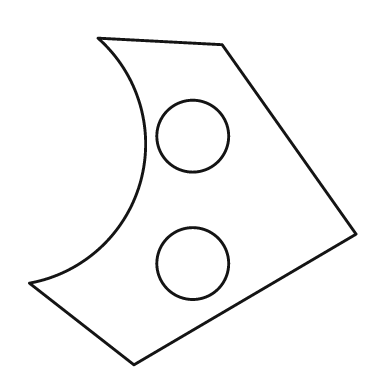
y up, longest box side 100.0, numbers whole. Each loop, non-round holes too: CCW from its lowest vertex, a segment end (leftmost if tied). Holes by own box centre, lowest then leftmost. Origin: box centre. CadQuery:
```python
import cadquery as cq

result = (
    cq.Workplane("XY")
    .moveTo(-18.0, -50.0)
    .lineTo(50.0, -10.0)
    .lineTo(9.0, 48.0)
    .lineTo(-29.0, 50.0)
    .threePointArc((-16.0, 6.0), (-50.0, -25.0))
    .close()
    .moveTo(0.0, -19.0)
    .circle(11.0)
    .moveTo(0.0, 20.0)
    .circle(11.0)
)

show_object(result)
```